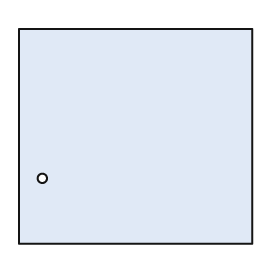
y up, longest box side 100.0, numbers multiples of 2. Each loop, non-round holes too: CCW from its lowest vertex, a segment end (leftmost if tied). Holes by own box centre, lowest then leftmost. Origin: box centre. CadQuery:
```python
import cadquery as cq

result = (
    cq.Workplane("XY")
    .moveTo(-50.0, -46.0)
    .lineTo(50.0, -46.0)
    .lineTo(50.0, 46.0)
    .lineTo(-50.0, 46.0)
    .close()
    .moveTo(-40.0, -18.0)
    .circle(2.0)
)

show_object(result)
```